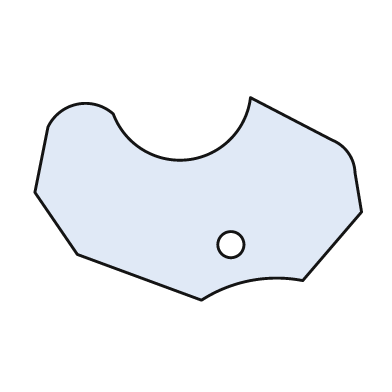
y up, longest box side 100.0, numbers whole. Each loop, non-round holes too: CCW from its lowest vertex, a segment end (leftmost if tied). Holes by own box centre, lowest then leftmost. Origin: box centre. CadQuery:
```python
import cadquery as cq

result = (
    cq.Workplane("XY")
    .moveTo(1.0, -31.0)
    .threePointArc((16.0, -25.0), (32.0, -25.0))
    .lineTo(50.0, -4.0)
    .lineTo(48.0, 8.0)
    .threePointArc((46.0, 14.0), (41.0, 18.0))
    .lineTo(16.0, 31.0)
    .threePointArc((-3.0, 12.0), (-26.0, 26.0))
    .threePointArc((-37.0, 29.0), (-46.0, 22.0))
    .lineTo(-50.0, 2.0)
    .lineTo(-37.0, -17.0)
    .close()
    .moveTo(10.0, -14.0)
    .circle(4.0)
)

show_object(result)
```